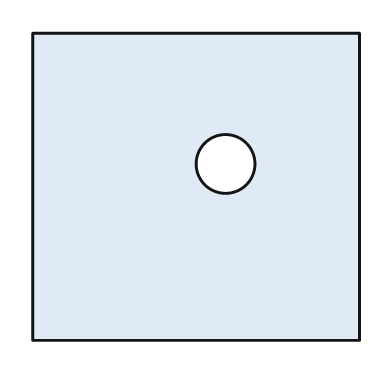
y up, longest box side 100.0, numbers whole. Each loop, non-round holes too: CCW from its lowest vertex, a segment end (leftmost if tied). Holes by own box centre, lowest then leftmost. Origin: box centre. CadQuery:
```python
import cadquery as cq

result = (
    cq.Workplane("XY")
    .moveTo(-50.0, -47.0)
    .lineTo(50.0, -47.0)
    .lineTo(50.0, 47.0)
    .lineTo(-50.0, 47.0)
    .close()
    .moveTo(9.0, 7.0)
    .circle(9.0)
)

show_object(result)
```